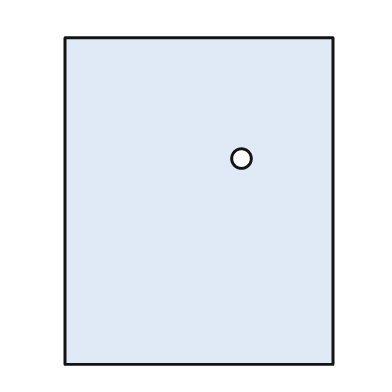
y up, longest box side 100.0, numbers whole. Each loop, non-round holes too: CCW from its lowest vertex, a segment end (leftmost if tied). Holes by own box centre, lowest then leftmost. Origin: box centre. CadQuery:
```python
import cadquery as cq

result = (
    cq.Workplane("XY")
    .moveTo(-41.0, -50.0)
    .lineTo(41.0, -50.0)
    .lineTo(41.0, 50.0)
    .lineTo(-41.0, 50.0)
    .close()
    .moveTo(13.0, 13.0)
    .circle(3.0)
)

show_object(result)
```